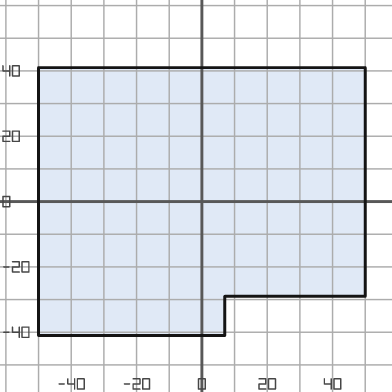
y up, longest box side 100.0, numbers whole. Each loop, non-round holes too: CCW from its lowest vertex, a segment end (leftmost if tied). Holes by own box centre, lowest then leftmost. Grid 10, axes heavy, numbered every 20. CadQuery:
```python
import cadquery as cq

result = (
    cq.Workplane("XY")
    .moveTo(-50.0, -41.0)
    .lineTo(7.0, -41.0)
    .lineTo(7.0, -29.0)
    .lineTo(50.0, -29.0)
    .lineTo(50.0, 41.0)
    .lineTo(-50.0, 41.0)
    .close()
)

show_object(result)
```